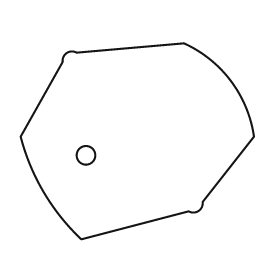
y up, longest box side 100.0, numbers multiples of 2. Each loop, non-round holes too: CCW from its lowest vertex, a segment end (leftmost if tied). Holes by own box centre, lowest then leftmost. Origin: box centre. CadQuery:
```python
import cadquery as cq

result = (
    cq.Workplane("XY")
    .moveTo(-24.0, -42.0)
    .lineTo(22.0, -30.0)
    .threePointArc((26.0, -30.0), (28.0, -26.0))
    .lineTo(50.0, 2.0)
    .threePointArc((40.0, 26.0), (20.0, 42.0))
    .lineTo(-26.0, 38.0)
    .threePointArc((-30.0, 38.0), (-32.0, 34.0))
    .lineTo(-50.0, 2.0)
    .threePointArc((-40.0, -22.0), (-24.0, -42.0))
    .close()
    .moveTo(-22.0, -6.0)
    .circle(4.0)
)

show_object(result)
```